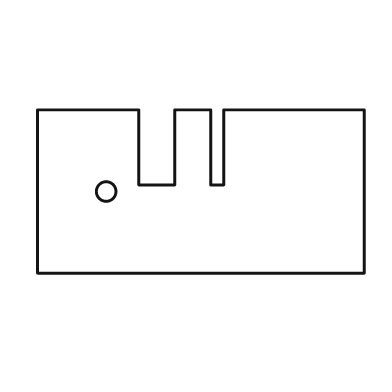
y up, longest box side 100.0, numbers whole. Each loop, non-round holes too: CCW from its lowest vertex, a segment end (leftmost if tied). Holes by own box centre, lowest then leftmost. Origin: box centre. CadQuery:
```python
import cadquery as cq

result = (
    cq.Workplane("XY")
    .moveTo(-50.0, -25.0)
    .lineTo(50.0, -25.0)
    .lineTo(50.0, 25.0)
    .lineTo(7.0, 25.0)
    .lineTo(7.0, 2.0)
    .lineTo(3.0, 2.0)
    .lineTo(3.0, 25.0)
    .lineTo(-8.0, 25.0)
    .lineTo(-8.0, 2.0)
    .lineTo(-19.0, 2.0)
    .lineTo(-19.0, 25.0)
    .lineTo(-50.0, 25.0)
    .close()
    .moveTo(-29.0, 0.0)
    .circle(3.0)
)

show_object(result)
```